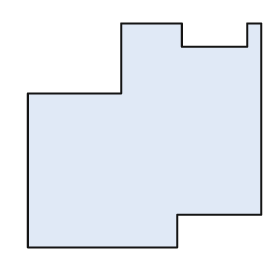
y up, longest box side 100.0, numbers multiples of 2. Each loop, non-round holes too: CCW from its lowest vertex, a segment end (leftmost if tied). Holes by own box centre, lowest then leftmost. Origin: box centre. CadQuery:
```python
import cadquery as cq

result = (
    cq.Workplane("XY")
    .moveTo(-50.0, -48.0)
    .lineTo(14.0, -48.0)
    .lineTo(14.0, -34.0)
    .lineTo(50.0, -34.0)
    .lineTo(50.0, 48.0)
    .lineTo(44.0, 48.0)
    .lineTo(44.0, 38.0)
    .lineTo(16.0, 38.0)
    .lineTo(16.0, 48.0)
    .lineTo(-10.0, 48.0)
    .lineTo(-10.0, 18.0)
    .lineTo(-50.0, 18.0)
    .close()
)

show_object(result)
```